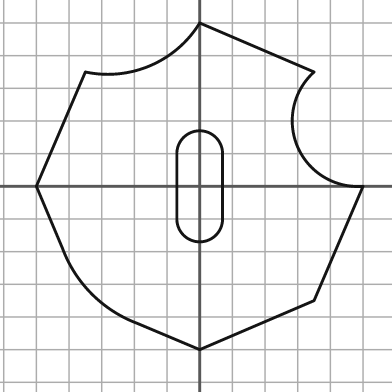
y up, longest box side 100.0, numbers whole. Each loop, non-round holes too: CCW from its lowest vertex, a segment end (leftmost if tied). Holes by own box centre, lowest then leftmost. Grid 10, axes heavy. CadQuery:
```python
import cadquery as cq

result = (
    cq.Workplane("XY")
    .moveTo(0.0, -50.0)
    .lineTo(35.0, -35.0)
    .lineTo(50.0, 0.0)
    .threePointArc((30.0, 12.0), (35.0, 35.0))
    .lineTo(0.0, 50.0)
    .threePointArc((-15.0, 37.0), (-35.0, 35.0))
    .lineTo(-50.0, 0.0)
    .lineTo(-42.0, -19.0)
    .threePointArc((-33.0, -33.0), (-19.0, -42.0))
    .close()
    .moveTo(-7.0, -10.0)
    .threePointArc((0.0, -17.0), (7.0, -10.0))
    .lineTo(7.0, 10.0)
    .threePointArc((0.0, 17.0), (-7.0, 10.0))
    .close()
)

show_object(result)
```